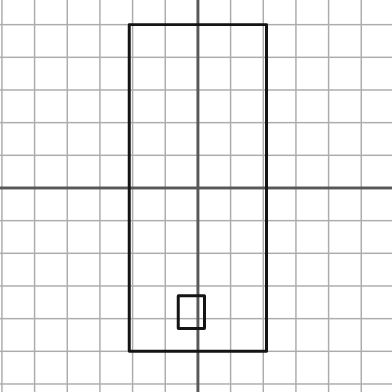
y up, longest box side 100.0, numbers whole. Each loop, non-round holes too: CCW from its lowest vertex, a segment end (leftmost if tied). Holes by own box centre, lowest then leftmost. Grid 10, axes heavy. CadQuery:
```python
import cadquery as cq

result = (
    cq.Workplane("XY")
    .moveTo(-21.0, -50.0)
    .lineTo(21.0, -50.0)
    .lineTo(21.0, 50.0)
    .lineTo(-21.0, 50.0)
    .close()
    .moveTo(-6.0, -43.0)
    .lineTo(2.0, -43.0)
    .lineTo(2.0, -33.0)
    .lineTo(-6.0, -33.0)
    .close()
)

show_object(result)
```